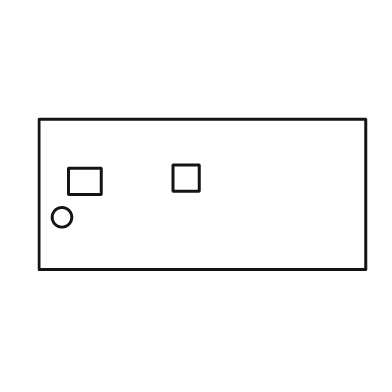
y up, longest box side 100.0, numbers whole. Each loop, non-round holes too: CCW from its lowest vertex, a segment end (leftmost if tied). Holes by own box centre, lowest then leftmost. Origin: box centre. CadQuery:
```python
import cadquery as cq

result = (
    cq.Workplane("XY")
    .moveTo(-50.0, -23.0)
    .lineTo(50.0, -23.0)
    .lineTo(50.0, 23.0)
    .lineTo(-50.0, 23.0)
    .close()
    .moveTo(-43.0, -7.0)
    .circle(3.0)
    .moveTo(-41.0, 0.0)
    .lineTo(-31.0, 0.0)
    .lineTo(-31.0, 8.0)
    .lineTo(-41.0, 8.0)
    .close()
    .moveTo(-9.0, 1.0)
    .lineTo(-1.0, 1.0)
    .lineTo(-1.0, 9.0)
    .lineTo(-9.0, 9.0)
    .close()
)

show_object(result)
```